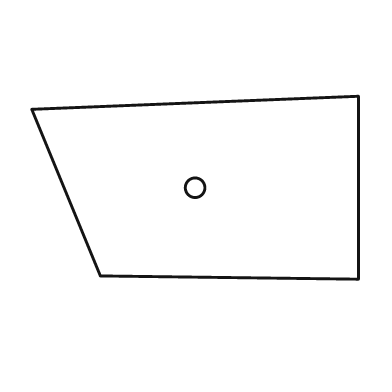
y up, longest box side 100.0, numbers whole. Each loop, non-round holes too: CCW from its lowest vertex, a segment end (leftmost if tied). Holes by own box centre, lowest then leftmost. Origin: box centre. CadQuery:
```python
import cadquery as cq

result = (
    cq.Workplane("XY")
    .moveTo(50.0, -28.0)
    .lineTo(50.0, 28.0)
    .lineTo(-50.0, 24.0)
    .lineTo(-29.0, -27.0)
    .close()
    .moveTo(0.0, 0.0)
    .circle(3.0)
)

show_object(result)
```